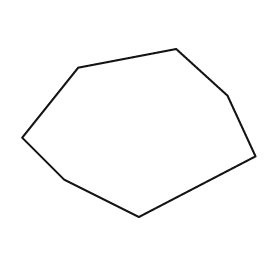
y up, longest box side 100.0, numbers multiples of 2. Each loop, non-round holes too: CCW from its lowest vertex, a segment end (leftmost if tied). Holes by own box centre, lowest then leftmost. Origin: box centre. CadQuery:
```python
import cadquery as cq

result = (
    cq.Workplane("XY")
    .moveTo(0.0, -36.0)
    .lineTo(50.0, -10.0)
    .lineTo(38.0, 16.0)
    .lineTo(16.0, 36.0)
    .lineTo(-26.0, 28.0)
    .lineTo(-50.0, -2.0)
    .lineTo(-32.0, -20.0)
    .close()
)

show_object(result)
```